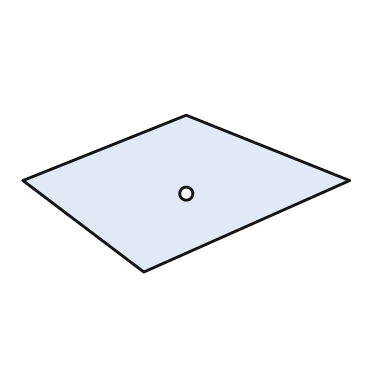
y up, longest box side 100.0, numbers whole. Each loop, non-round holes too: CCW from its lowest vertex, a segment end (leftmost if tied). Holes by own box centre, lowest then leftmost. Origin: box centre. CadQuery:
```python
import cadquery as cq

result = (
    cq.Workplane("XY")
    .moveTo(-13.0, -24.0)
    .lineTo(50.0, 4.0)
    .lineTo(0.0, 24.0)
    .lineTo(-50.0, 4.0)
    .close()
    .moveTo(0.0, 0.0)
    .circle(2.0)
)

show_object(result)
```